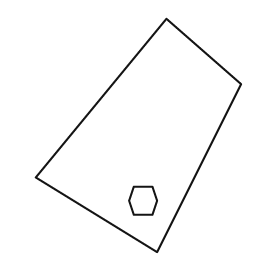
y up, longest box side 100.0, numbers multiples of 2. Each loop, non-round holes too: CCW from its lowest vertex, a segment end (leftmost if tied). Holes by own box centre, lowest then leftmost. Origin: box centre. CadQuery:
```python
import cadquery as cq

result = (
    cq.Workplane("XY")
    .moveTo(8.0, -50.0)
    .lineTo(44.0, 22.0)
    .lineTo(12.0, 50.0)
    .lineTo(-44.0, -18.0)
    .close()
    .moveTo(-2.0, -34.0)
    .lineTo(6.0, -34.0)
    .lineTo(8.0, -28.0)
    .lineTo(6.0, -22.0)
    .lineTo(-2.0, -22.0)
    .lineTo(-4.0, -28.0)
    .close()
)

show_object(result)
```